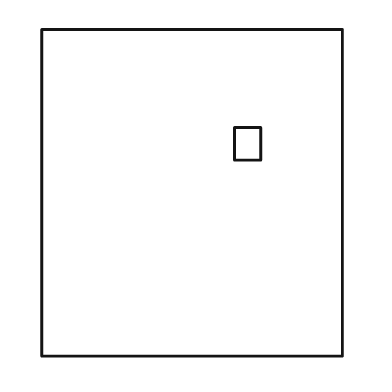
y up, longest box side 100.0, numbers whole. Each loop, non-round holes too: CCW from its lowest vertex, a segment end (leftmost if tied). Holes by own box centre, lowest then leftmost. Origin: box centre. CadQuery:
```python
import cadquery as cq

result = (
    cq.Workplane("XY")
    .moveTo(-46.0, -50.0)
    .lineTo(46.0, -50.0)
    .lineTo(46.0, 50.0)
    .lineTo(-46.0, 50.0)
    .close()
    .moveTo(13.0, 10.0)
    .lineTo(21.0, 10.0)
    .lineTo(21.0, 20.0)
    .lineTo(13.0, 20.0)
    .close()
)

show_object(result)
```